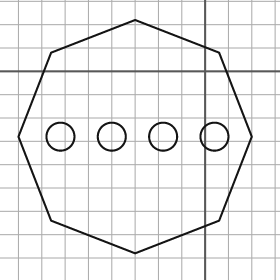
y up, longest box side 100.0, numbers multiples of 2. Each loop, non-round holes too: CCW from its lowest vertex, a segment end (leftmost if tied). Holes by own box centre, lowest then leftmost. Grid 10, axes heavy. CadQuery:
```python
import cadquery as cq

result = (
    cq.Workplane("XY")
    .moveTo(-30.0, -78.0)
    .lineTo(6.0, -64.0)
    .lineTo(20.0, -28.0)
    .lineTo(6.0, 8.0)
    .lineTo(-30.0, 22.0)
    .lineTo(-66.0, 8.0)
    .lineTo(-80.0, -28.0)
    .lineTo(-66.0, -64.0)
    .close()
    .moveTo(-62.0, -28.0)
    .circle(6.0)
    .moveTo(-40.0, -28.0)
    .circle(6.0)
    .moveTo(-18.0, -28.0)
    .circle(6.0)
    .moveTo(4.0, -28.0)
    .circle(6.0)
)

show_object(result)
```